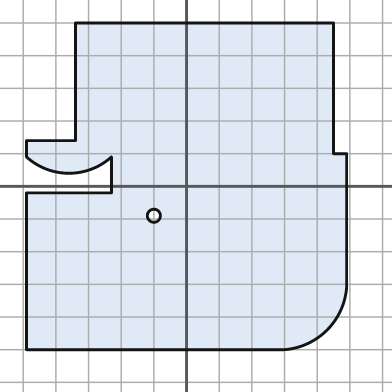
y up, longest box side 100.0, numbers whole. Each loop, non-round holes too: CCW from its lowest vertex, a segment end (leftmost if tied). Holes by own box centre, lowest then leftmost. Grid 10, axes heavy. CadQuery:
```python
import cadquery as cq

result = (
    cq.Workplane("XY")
    .moveTo(-49.0, -50.0)
    .lineTo(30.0, -50.0)
    .threePointArc((43.0, -44.0), (49.0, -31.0))
    .lineTo(49.0, 10.0)
    .lineTo(45.0, 10.0)
    .lineTo(45.0, 50.0)
    .lineTo(-34.0, 50.0)
    .lineTo(-34.0, 14.0)
    .lineTo(-49.0, 14.0)
    .lineTo(-49.0, 9.0)
    .threePointArc((-36.0, 4.0), (-23.0, 9.0))
    .lineTo(-23.0, -2.0)
    .lineTo(-49.0, -2.0)
    .close()
    .moveTo(-10.0, -9.0)
    .circle(2.0)
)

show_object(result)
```